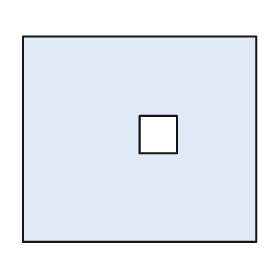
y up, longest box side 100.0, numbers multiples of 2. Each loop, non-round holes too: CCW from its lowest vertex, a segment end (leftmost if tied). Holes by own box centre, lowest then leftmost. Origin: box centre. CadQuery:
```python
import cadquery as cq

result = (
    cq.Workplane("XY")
    .moveTo(-50.0, -44.0)
    .lineTo(50.0, -44.0)
    .lineTo(50.0, 44.0)
    .lineTo(-50.0, 44.0)
    .close()
    .moveTo(0.0, -6.0)
    .lineTo(16.0, -6.0)
    .lineTo(16.0, 10.0)
    .lineTo(0.0, 10.0)
    .close()
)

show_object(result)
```